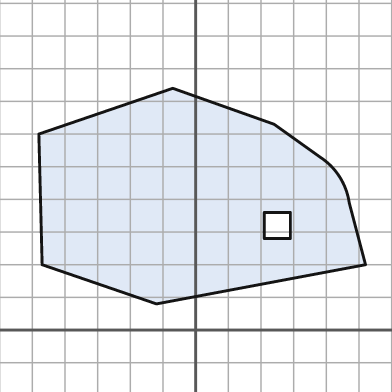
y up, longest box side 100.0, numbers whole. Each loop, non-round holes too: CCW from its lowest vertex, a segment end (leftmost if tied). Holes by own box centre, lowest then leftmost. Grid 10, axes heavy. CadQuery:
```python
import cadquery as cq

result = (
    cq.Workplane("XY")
    .moveTo(-12.0, 8.0)
    .lineTo(52.0, 20.0)
    .lineTo(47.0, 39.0)
    .threePointArc((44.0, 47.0), (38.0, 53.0))
    .lineTo(24.0, 63.0)
    .lineTo(-7.0, 74.0)
    .lineTo(-48.0, 60.0)
    .lineTo(-47.0, 20.0)
    .close()
    .moveTo(21.0, 28.0)
    .lineTo(29.0, 28.0)
    .lineTo(29.0, 36.0)
    .lineTo(21.0, 36.0)
    .close()
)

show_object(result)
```